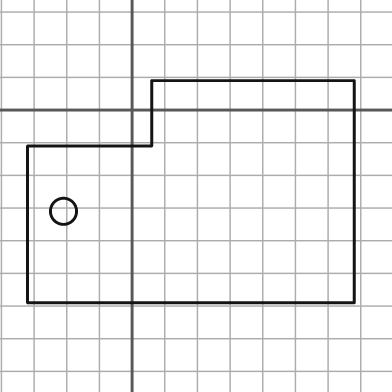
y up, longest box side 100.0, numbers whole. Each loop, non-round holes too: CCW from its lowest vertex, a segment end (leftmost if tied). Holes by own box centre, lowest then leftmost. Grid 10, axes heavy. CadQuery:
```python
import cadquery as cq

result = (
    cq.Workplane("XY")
    .moveTo(-32.0, -59.0)
    .lineTo(68.0, -59.0)
    .lineTo(68.0, 9.0)
    .lineTo(6.0, 9.0)
    .lineTo(6.0, -11.0)
    .lineTo(-32.0, -11.0)
    .close()
    .moveTo(-21.0, -31.0)
    .circle(4.0)
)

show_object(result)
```